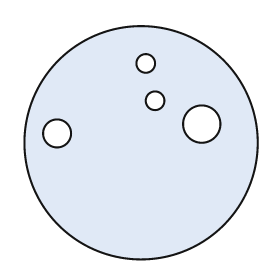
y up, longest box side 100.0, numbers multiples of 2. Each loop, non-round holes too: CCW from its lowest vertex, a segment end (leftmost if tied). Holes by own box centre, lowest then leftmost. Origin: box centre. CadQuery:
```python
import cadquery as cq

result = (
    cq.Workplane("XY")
    .moveTo(0.0, 0.0)
    .circle(50.0)
    .moveTo(-36.0, 4.0)
    .circle(6.0)
    .moveTo(26.0, 8.0)
    .circle(8.0)
    .moveTo(6.0, 18.0)
    .circle(4.0)
    .moveTo(2.0, 34.0)
    .circle(4.0)
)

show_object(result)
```